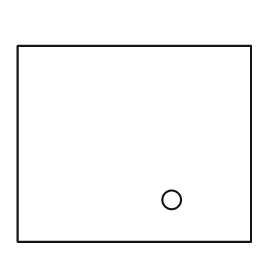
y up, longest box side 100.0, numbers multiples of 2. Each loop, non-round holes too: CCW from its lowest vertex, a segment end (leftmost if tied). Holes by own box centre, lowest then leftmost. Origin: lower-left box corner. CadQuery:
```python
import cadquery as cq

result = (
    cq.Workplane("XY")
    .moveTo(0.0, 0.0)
    .lineTo(100.0, 0.0)
    .lineTo(100.0, 84.0)
    .lineTo(0.0, 84.0)
    .close()
    .moveTo(66.0, 18.0)
    .circle(4.0)
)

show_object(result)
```